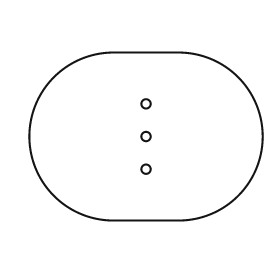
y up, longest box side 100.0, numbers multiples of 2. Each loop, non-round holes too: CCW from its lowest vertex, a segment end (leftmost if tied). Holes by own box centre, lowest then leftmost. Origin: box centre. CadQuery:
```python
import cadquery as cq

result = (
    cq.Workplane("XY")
    .moveTo(-14.0, -36.0)
    .lineTo(14.0, -36.0)
    .threePointArc((50.0, 0.0), (14.0, 36.0))
    .lineTo(-14.0, 36.0)
    .threePointArc((-50.0, 0.0), (-14.0, -36.0))
    .close()
    .moveTo(0.0, -14.0)
    .circle(2.0)
    .moveTo(0.0, 0.0)
    .circle(2.0)
    .moveTo(0.0, 14.0)
    .circle(2.0)
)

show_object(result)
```